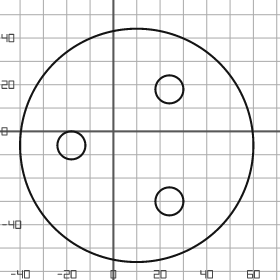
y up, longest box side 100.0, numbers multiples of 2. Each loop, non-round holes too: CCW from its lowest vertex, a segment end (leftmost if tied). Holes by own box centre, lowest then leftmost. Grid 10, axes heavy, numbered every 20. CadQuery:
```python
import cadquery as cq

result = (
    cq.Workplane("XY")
    .moveTo(10.0, -6.0)
    .circle(50.0)
    .moveTo(24.0, -30.0)
    .circle(6.0)
    .moveTo(-18.0, -6.0)
    .circle(6.0)
    .moveTo(24.0, 18.0)
    .circle(6.0)
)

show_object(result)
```